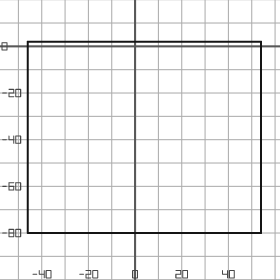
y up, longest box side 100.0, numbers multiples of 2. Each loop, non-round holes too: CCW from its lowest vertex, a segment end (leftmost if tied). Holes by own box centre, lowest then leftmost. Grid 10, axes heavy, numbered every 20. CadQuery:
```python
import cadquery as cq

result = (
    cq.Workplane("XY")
    .moveTo(-46.0, -80.0)
    .lineTo(54.0, -80.0)
    .lineTo(54.0, 2.0)
    .lineTo(-46.0, 2.0)
    .close()
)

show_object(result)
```